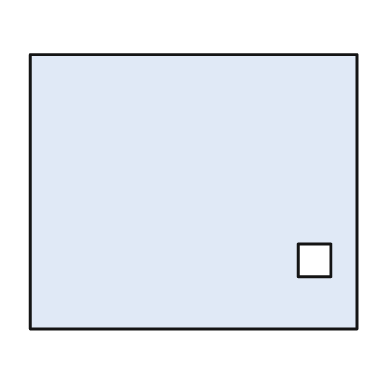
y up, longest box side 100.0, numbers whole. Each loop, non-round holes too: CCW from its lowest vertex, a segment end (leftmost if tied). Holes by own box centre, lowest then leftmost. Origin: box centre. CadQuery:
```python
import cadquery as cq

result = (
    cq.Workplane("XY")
    .moveTo(-50.0, -42.0)
    .lineTo(50.0, -42.0)
    .lineTo(50.0, 42.0)
    .lineTo(-50.0, 42.0)
    .close()
    .moveTo(32.0, -26.0)
    .lineTo(42.0, -26.0)
    .lineTo(42.0, -16.0)
    .lineTo(32.0, -16.0)
    .close()
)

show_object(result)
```